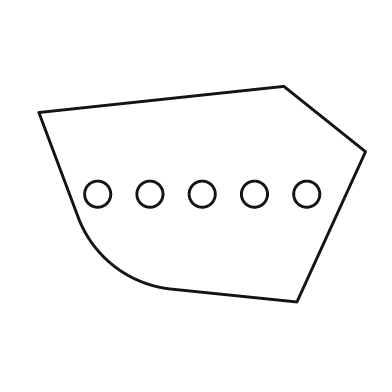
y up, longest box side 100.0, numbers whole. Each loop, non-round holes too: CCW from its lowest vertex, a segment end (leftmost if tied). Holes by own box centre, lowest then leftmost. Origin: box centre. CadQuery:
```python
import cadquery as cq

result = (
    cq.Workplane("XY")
    .moveTo(29.0, -33.0)
    .lineTo(50.0, 13.0)
    .lineTo(25.0, 33.0)
    .lineTo(-50.0, 25.0)
    .lineTo(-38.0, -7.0)
    .threePointArc((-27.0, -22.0), (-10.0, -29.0))
    .close()
    .moveTo(-32.0, 0.0)
    .circle(4.0)
    .moveTo(-16.0, 0.0)
    .circle(4.0)
    .moveTo(0.0, 0.0)
    .circle(4.0)
    .moveTo(16.0, 0.0)
    .circle(4.0)
    .moveTo(32.0, 0.0)
    .circle(4.0)
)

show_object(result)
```